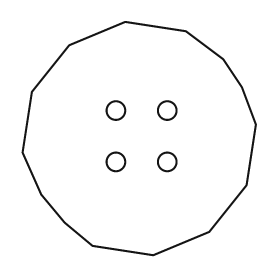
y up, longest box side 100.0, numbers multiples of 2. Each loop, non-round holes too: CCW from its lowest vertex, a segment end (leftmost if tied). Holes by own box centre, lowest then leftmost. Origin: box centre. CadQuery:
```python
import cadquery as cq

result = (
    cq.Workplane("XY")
    .moveTo(6.0, -50.0)
    .lineTo(30.0, -40.0)
    .lineTo(46.0, -20.0)
    .lineTo(50.0, 6.0)
    .lineTo(44.0, 22.0)
    .lineTo(36.0, 34.0)
    .lineTo(20.0, 46.0)
    .lineTo(-6.0, 50.0)
    .lineTo(-30.0, 40.0)
    .lineTo(-46.0, 20.0)
    .lineTo(-50.0, -6.0)
    .lineTo(-42.0, -24.0)
    .lineTo(-32.0, -36.0)
    .lineTo(-20.0, -46.0)
    .close()
    .moveTo(-10.0, -10.0)
    .circle(4.0)
    .moveTo(12.0, -10.0)
    .circle(4.0)
    .moveTo(-10.0, 12.0)
    .circle(4.0)
    .moveTo(12.0, 12.0)
    .circle(4.0)
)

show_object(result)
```